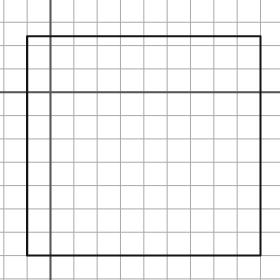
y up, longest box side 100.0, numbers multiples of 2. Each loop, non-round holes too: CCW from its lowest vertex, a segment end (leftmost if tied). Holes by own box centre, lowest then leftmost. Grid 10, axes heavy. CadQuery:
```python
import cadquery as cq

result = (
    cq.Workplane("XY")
    .moveTo(-10.0, -70.0)
    .lineTo(90.0, -70.0)
    .lineTo(90.0, 24.0)
    .lineTo(-10.0, 24.0)
    .close()
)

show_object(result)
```